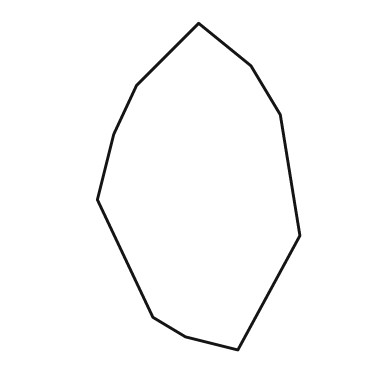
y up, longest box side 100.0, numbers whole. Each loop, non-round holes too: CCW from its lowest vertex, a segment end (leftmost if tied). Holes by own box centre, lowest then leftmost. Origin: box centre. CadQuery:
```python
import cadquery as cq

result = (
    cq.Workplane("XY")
    .moveTo(12.0, -50.0)
    .lineTo(31.0, -15.0)
    .lineTo(25.0, 22.0)
    .lineTo(16.0, 37.0)
    .lineTo(0.0, 50.0)
    .lineTo(-19.0, 31.0)
    .lineTo(-26.0, 16.0)
    .lineTo(-31.0, -4.0)
    .lineTo(-14.0, -40.0)
    .lineTo(-4.0, -46.0)
    .close()
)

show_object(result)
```